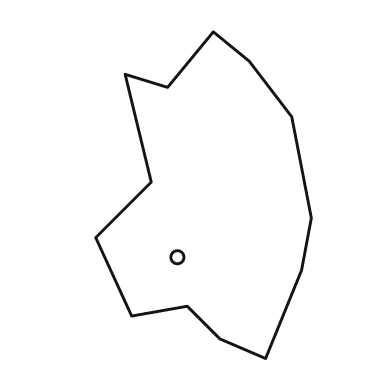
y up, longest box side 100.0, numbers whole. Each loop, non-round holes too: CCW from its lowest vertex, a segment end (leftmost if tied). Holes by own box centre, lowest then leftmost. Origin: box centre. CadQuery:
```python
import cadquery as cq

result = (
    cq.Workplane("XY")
    .moveTo(19.0, -50.0)
    .lineTo(30.0, -23.0)
    .lineTo(33.0, -7.0)
    .lineTo(27.0, 24.0)
    .lineTo(14.0, 41.0)
    .lineTo(3.0, 50.0)
    .lineTo(-11.0, 33.0)
    .lineTo(-24.0, 37.0)
    .lineTo(-16.0, 4.0)
    .lineTo(-33.0, -13.0)
    .lineTo(-22.0, -37.0)
    .lineTo(-5.0, -34.0)
    .lineTo(5.0, -44.0)
    .close()
    .moveTo(-8.0, -19.0)
    .circle(2.0)
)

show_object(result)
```